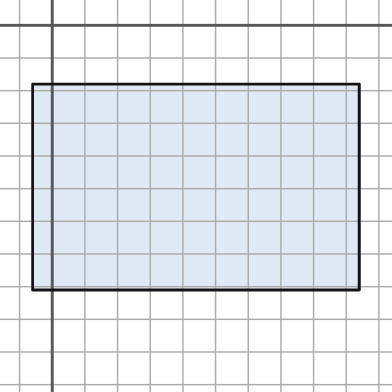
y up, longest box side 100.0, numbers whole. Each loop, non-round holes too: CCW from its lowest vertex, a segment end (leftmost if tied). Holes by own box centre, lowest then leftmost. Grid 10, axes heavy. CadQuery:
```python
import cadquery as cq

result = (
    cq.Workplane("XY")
    .moveTo(-6.0, -81.0)
    .lineTo(94.0, -81.0)
    .lineTo(94.0, -18.0)
    .lineTo(-6.0, -18.0)
    .close()
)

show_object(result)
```